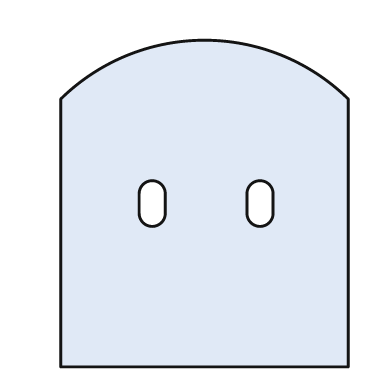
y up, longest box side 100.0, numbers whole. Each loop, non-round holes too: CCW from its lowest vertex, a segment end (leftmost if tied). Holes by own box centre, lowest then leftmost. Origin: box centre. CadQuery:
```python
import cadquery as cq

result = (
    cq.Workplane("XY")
    .moveTo(-44.0, -50.0)
    .lineTo(44.0, -50.0)
    .lineTo(44.0, 32.0)
    .threePointArc((0.0, 50.0), (-44.0, 32.0))
    .close()
    .moveTo(-20.0, -3.0)
    .threePointArc((-16.0, -7.0), (-12.0, -3.0))
    .lineTo(-12.0, 3.0)
    .threePointArc((-16.0, 7.0), (-20.0, 3.0))
    .close()
    .moveTo(13.0, -3.0)
    .threePointArc((17.0, -7.0), (21.0, -3.0))
    .lineTo(21.0, 3.0)
    .threePointArc((17.0, 7.0), (13.0, 3.0))
    .close()
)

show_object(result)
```